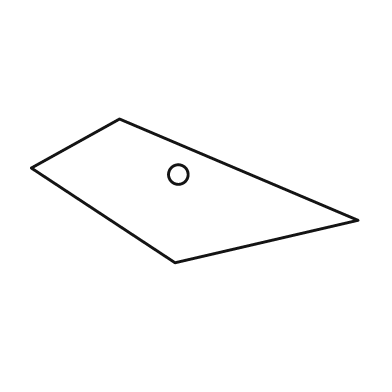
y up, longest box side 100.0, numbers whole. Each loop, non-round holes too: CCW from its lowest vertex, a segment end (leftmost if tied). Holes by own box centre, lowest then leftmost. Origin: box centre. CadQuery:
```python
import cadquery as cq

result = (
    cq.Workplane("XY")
    .moveTo(-6.0, -22.0)
    .lineTo(50.0, -9.0)
    .lineTo(-23.0, 22.0)
    .lineTo(-50.0, 7.0)
    .close()
    .moveTo(-5.0, 5.0)
    .circle(3.0)
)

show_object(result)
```